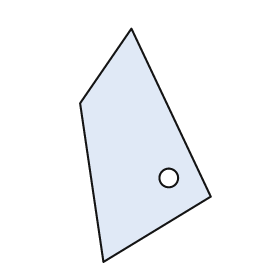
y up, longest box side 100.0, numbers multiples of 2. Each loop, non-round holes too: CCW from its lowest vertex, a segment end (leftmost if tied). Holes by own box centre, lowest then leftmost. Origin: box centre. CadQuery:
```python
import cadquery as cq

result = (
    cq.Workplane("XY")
    .moveTo(-18.0, -50.0)
    .lineTo(28.0, -22.0)
    .lineTo(-6.0, 50.0)
    .lineTo(-28.0, 18.0)
    .close()
    .moveTo(10.0, -14.0)
    .circle(4.0)
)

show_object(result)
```